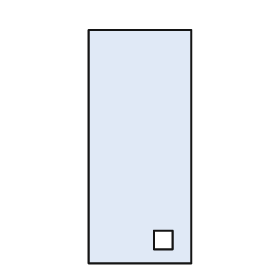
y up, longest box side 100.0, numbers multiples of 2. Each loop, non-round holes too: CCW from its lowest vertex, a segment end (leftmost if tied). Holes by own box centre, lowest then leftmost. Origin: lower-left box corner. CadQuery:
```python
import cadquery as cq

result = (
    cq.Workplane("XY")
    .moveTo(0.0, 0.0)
    .lineTo(44.0, 0.0)
    .lineTo(44.0, 100.0)
    .lineTo(0.0, 100.0)
    .close()
    .moveTo(28.0, 6.0)
    .lineTo(36.0, 6.0)
    .lineTo(36.0, 14.0)
    .lineTo(28.0, 14.0)
    .close()
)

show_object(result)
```